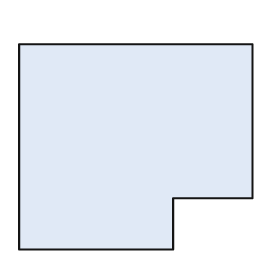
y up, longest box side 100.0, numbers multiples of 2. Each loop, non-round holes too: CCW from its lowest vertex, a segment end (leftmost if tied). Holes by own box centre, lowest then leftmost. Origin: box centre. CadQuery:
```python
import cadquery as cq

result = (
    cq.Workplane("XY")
    .moveTo(-50.0, -44.0)
    .lineTo(16.0, -44.0)
    .lineTo(16.0, -22.0)
    .lineTo(50.0, -22.0)
    .lineTo(50.0, 44.0)
    .lineTo(-50.0, 44.0)
    .close()
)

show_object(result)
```